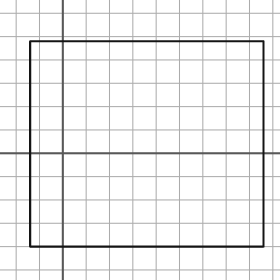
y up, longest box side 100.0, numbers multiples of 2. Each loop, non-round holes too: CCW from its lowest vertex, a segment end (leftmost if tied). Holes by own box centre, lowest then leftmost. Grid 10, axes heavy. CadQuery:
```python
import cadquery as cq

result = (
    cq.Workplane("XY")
    .moveTo(-14.0, -40.0)
    .lineTo(86.0, -40.0)
    .lineTo(86.0, 48.0)
    .lineTo(-14.0, 48.0)
    .close()
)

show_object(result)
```